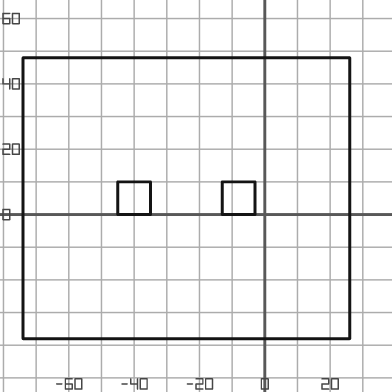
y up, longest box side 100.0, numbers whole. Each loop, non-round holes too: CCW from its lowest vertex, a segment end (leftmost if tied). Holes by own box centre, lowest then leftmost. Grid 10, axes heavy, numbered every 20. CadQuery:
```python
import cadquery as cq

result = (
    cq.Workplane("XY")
    .moveTo(-74.0, -38.0)
    .lineTo(26.0, -38.0)
    .lineTo(26.0, 48.0)
    .lineTo(-74.0, 48.0)
    .close()
    .moveTo(-45.0, 0.0)
    .lineTo(-35.0, 0.0)
    .lineTo(-35.0, 10.0)
    .lineTo(-45.0, 10.0)
    .close()
    .moveTo(-13.0, 0.0)
    .lineTo(-3.0, 0.0)
    .lineTo(-3.0, 10.0)
    .lineTo(-13.0, 10.0)
    .close()
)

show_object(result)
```